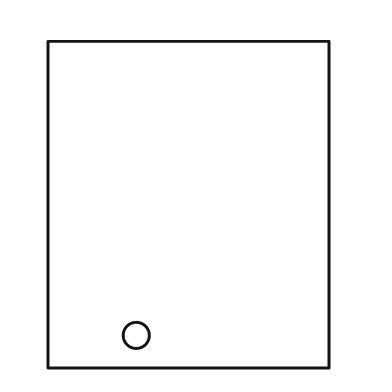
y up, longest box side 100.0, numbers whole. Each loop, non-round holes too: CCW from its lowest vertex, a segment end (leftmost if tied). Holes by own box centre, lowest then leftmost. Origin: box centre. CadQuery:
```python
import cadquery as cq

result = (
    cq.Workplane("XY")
    .moveTo(-43.0, -50.0)
    .lineTo(43.0, -50.0)
    .lineTo(43.0, 50.0)
    .lineTo(-43.0, 50.0)
    .close()
    .moveTo(-16.0, -40.0)
    .circle(4.0)
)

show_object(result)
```